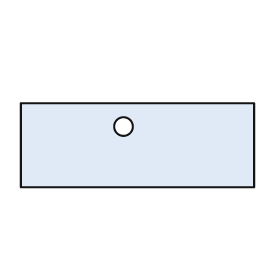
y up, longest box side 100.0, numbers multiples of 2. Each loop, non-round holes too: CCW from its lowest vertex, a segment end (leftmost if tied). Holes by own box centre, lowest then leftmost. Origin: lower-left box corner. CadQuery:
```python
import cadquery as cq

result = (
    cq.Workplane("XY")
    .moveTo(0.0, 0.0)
    .lineTo(100.0, 0.0)
    .lineTo(100.0, 36.0)
    .lineTo(0.0, 36.0)
    .close()
    .moveTo(44.0, 26.0)
    .circle(4.0)
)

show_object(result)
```